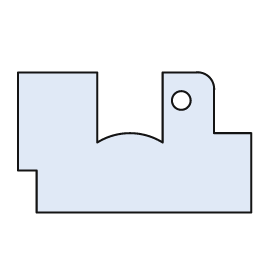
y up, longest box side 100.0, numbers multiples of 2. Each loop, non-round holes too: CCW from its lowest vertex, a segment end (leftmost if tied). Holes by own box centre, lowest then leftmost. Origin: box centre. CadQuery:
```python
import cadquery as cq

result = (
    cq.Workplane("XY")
    .moveTo(-42.0, -30.0)
    .lineTo(50.0, -30.0)
    .lineTo(50.0, 4.0)
    .lineTo(34.0, 4.0)
    .lineTo(34.0, 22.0)
    .threePointArc((32.0, 28.0), (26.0, 30.0))
    .lineTo(12.0, 30.0)
    .lineTo(12.0, 0.0)
    .threePointArc((-2.0, 4.0), (-16.0, 0.0))
    .lineTo(-16.0, 30.0)
    .lineTo(-50.0, 30.0)
    .lineTo(-50.0, -12.0)
    .lineTo(-42.0, -12.0)
    .close()
    .moveTo(20.0, 18.0)
    .circle(4.0)
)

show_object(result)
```